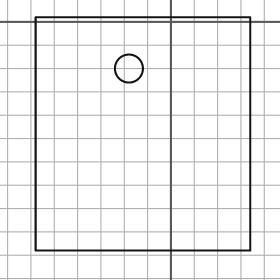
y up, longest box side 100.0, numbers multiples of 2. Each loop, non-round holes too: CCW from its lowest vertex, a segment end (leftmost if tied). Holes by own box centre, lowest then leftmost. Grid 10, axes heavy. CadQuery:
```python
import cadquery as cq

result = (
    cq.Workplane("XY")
    .moveTo(-58.0, -98.0)
    .lineTo(34.0, -98.0)
    .lineTo(34.0, 2.0)
    .lineTo(-58.0, 2.0)
    .close()
    .moveTo(-18.0, -20.0)
    .circle(6.0)
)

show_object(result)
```